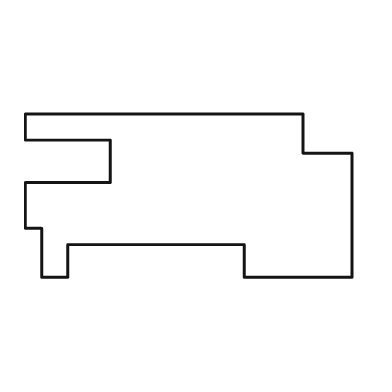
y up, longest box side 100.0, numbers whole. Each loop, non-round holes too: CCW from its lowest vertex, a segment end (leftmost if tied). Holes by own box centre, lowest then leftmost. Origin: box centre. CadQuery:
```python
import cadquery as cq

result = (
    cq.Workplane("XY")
    .moveTo(-45.0, -25.0)
    .lineTo(-37.0, -25.0)
    .lineTo(-37.0, -15.0)
    .lineTo(17.0, -15.0)
    .lineTo(17.0, -25.0)
    .lineTo(50.0, -25.0)
    .lineTo(50.0, 13.0)
    .lineTo(35.0, 13.0)
    .lineTo(35.0, 25.0)
    .lineTo(-50.0, 25.0)
    .lineTo(-50.0, 17.0)
    .lineTo(-24.0, 17.0)
    .lineTo(-24.0, 4.0)
    .lineTo(-50.0, 4.0)
    .lineTo(-50.0, -10.0)
    .lineTo(-45.0, -10.0)
    .close()
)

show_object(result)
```